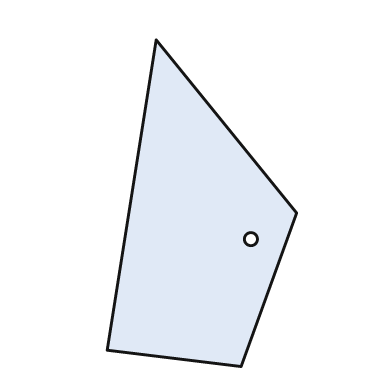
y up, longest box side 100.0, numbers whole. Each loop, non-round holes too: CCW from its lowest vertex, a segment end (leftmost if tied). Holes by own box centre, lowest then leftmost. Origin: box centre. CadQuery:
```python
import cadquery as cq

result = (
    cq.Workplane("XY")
    .moveTo(12.0, -50.0)
    .lineTo(29.0, -3.0)
    .lineTo(-14.0, 50.0)
    .lineTo(-29.0, -45.0)
    .close()
    .moveTo(15.0, -11.0)
    .circle(2.0)
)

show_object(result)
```